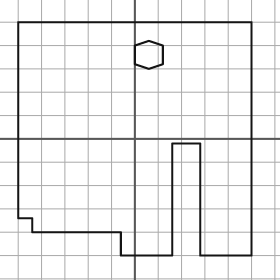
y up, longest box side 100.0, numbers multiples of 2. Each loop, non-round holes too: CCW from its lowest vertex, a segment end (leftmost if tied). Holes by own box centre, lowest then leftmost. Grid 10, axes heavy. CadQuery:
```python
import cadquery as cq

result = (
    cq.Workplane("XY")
    .moveTo(-6.0, -50.0)
    .lineTo(16.0, -50.0)
    .lineTo(16.0, -2.0)
    .lineTo(28.0, -2.0)
    .lineTo(28.0, -50.0)
    .lineTo(50.0, -50.0)
    .lineTo(50.0, 50.0)
    .lineTo(-50.0, 50.0)
    .lineTo(-50.0, -34.0)
    .lineTo(-44.0, -34.0)
    .lineTo(-44.0, -40.0)
    .lineTo(-6.0, -40.0)
    .close()
    .moveTo(6.0, 30.0)
    .lineTo(12.0, 32.0)
    .lineTo(12.0, 40.0)
    .lineTo(6.0, 42.0)
    .lineTo(0.0, 40.0)
    .lineTo(0.0, 32.0)
    .close()
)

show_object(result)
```